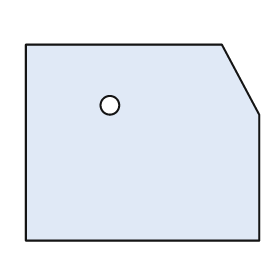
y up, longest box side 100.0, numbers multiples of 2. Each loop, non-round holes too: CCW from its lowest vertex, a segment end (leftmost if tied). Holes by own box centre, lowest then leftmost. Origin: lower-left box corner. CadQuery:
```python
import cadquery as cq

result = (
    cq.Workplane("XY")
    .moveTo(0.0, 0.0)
    .lineTo(100.0, 0.0)
    .lineTo(100.0, 54.0)
    .lineTo(84.0, 84.0)
    .lineTo(0.0, 84.0)
    .close()
    .moveTo(36.0, 58.0)
    .circle(4.0)
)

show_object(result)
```